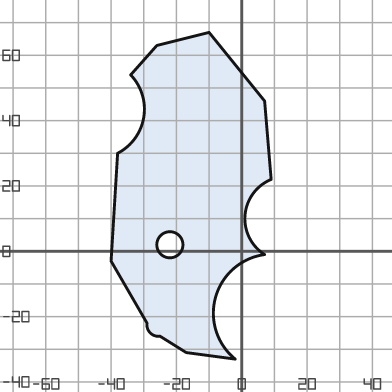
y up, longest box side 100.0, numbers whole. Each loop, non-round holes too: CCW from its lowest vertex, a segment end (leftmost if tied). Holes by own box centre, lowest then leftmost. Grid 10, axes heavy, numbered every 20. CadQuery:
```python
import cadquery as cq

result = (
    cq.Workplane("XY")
    .moveTo(-2.0, -33.0)
    .threePointArc((-8.0, -14.0), (7.0, -1.0))
    .threePointArc((1.0, 11.0), (9.0, 22.0))
    .lineTo(7.0, 46.0)
    .lineTo(-10.0, 67.0)
    .lineTo(-26.0, 63.0)
    .lineTo(-34.0, 54.0)
    .threePointArc((-30.0, 41.0), (-38.0, 30.0))
    .lineTo(-40.0, -3.0)
    .lineTo(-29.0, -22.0)
    .threePointArc((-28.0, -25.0), (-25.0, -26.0))
    .lineTo(-17.0, -31.0)
    .close()
    .moveTo(-22.0, 2.0)
    .circle(4.0)
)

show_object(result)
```